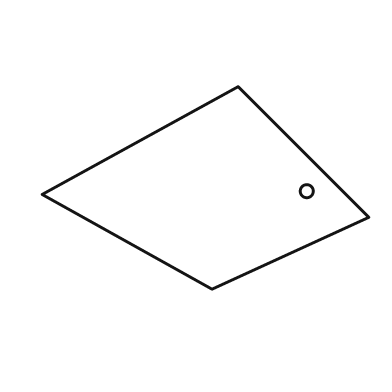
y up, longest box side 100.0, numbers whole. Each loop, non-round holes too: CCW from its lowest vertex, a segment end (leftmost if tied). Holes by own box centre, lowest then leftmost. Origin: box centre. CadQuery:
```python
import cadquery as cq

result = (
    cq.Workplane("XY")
    .moveTo(2.0, -31.0)
    .lineTo(50.0, -9.0)
    .lineTo(10.0, 31.0)
    .lineTo(-50.0, -2.0)
    .close()
    .moveTo(31.0, -1.0)
    .circle(2.0)
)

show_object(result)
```